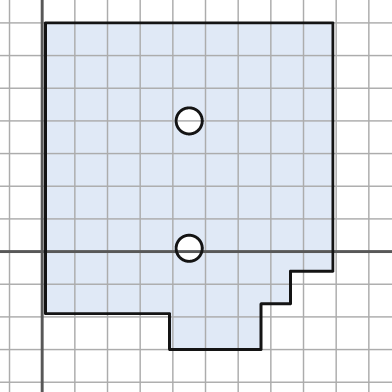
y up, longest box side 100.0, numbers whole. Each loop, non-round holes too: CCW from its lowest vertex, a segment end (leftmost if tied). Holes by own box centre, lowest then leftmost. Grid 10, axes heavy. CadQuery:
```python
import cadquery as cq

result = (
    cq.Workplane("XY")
    .moveTo(39.0, -30.0)
    .lineTo(67.0, -30.0)
    .lineTo(67.0, -16.0)
    .lineTo(76.0, -16.0)
    .lineTo(76.0, -6.0)
    .lineTo(89.0, -6.0)
    .lineTo(89.0, 70.0)
    .lineTo(1.0, 70.0)
    .lineTo(1.0, -19.0)
    .lineTo(39.0, -19.0)
    .close()
    .moveTo(45.0, 1.0)
    .circle(4.0)
    .moveTo(45.0, 40.0)
    .circle(4.0)
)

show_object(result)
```